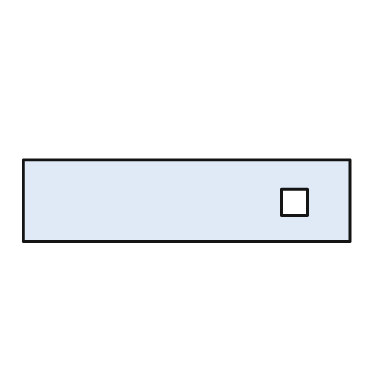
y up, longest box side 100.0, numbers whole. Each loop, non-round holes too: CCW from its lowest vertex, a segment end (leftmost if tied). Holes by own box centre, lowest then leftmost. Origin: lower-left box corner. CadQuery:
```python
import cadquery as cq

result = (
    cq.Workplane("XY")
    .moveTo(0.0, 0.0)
    .lineTo(100.0, 0.0)
    .lineTo(100.0, 25.0)
    .lineTo(0.0, 25.0)
    .close()
    .moveTo(79.0, 8.0)
    .lineTo(87.0, 8.0)
    .lineTo(87.0, 16.0)
    .lineTo(79.0, 16.0)
    .close()
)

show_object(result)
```